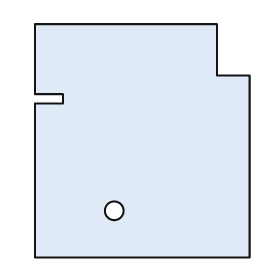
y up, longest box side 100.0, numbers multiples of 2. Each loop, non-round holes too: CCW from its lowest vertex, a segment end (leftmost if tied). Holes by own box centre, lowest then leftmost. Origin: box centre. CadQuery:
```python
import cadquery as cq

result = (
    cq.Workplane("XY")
    .moveTo(-46.0, -50.0)
    .lineTo(46.0, -50.0)
    .lineTo(46.0, 28.0)
    .lineTo(32.0, 28.0)
    .lineTo(32.0, 50.0)
    .lineTo(-46.0, 50.0)
    .lineTo(-46.0, 20.0)
    .lineTo(-34.0, 20.0)
    .lineTo(-34.0, 16.0)
    .lineTo(-46.0, 16.0)
    .close()
    .moveTo(-12.0, -30.0)
    .circle(4.0)
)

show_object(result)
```